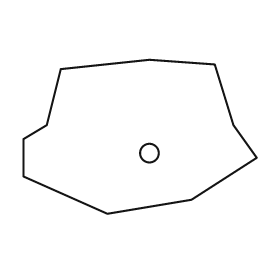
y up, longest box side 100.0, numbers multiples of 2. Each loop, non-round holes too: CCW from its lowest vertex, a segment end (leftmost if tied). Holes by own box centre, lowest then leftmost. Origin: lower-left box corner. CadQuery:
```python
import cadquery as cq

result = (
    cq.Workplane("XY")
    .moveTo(36.0, 0.0)
    .lineTo(72.0, 6.0)
    .lineTo(100.0, 24.0)
    .lineTo(90.0, 38.0)
    .lineTo(82.0, 64.0)
    .lineTo(54.0, 66.0)
    .lineTo(16.0, 62.0)
    .lineTo(10.0, 38.0)
    .lineTo(0.0, 32.0)
    .lineTo(0.0, 16.0)
    .close()
    .moveTo(54.0, 26.0)
    .circle(4.0)
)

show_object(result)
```